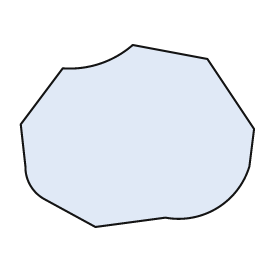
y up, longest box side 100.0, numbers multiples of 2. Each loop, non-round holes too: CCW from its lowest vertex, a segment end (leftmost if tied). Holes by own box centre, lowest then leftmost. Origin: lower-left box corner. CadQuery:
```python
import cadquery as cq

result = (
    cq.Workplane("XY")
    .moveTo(32.0, 0.0)
    .lineTo(62.0, 4.0)
    .threePointArc((84.0, 8.0), (98.0, 26.0))
    .lineTo(100.0, 42.0)
    .lineTo(80.0, 72.0)
    .lineTo(48.0, 78.0)
    .threePointArc((34.0, 70.0), (18.0, 68.0))
    .lineTo(0.0, 44.0)
    .lineTo(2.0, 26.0)
    .threePointArc((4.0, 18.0), (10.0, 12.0))
    .close()
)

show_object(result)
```